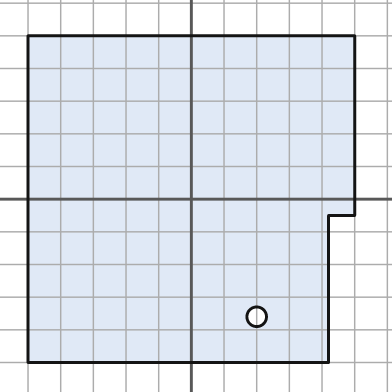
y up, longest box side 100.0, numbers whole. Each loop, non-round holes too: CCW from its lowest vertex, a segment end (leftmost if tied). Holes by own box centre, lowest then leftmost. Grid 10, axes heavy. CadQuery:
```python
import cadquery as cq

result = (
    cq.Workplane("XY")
    .moveTo(-50.0, -50.0)
    .lineTo(42.0, -50.0)
    .lineTo(42.0, -5.0)
    .lineTo(50.0, -5.0)
    .lineTo(50.0, 50.0)
    .lineTo(-50.0, 50.0)
    .close()
    .moveTo(20.0, -36.0)
    .circle(3.0)
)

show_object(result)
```